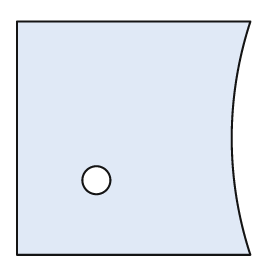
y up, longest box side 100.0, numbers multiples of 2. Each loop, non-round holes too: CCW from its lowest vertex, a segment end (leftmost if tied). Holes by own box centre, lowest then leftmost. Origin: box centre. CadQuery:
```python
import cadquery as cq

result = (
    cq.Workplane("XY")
    .moveTo(-50.0, -50.0)
    .lineTo(50.0, -50.0)
    .threePointArc((42.0, 0.0), (50.0, 50.0))
    .lineTo(-50.0, 50.0)
    .close()
    .moveTo(-16.0, -18.0)
    .circle(6.0)
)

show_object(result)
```